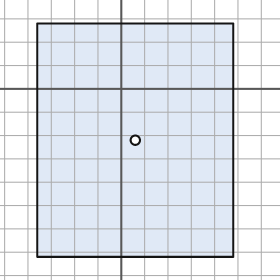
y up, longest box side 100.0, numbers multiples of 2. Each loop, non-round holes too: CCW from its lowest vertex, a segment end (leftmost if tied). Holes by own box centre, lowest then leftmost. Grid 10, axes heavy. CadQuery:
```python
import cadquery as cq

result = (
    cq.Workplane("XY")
    .moveTo(-36.0, -72.0)
    .lineTo(48.0, -72.0)
    .lineTo(48.0, 28.0)
    .lineTo(-36.0, 28.0)
    .close()
    .moveTo(6.0, -22.0)
    .circle(2.0)
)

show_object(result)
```